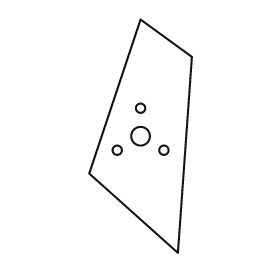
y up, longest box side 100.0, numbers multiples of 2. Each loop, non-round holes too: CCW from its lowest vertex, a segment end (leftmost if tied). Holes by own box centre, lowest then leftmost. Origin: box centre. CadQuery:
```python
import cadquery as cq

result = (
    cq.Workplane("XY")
    .moveTo(16.0, -50.0)
    .lineTo(22.0, 34.0)
    .lineTo(0.0, 50.0)
    .lineTo(-22.0, -16.0)
    .close()
    .moveTo(-10.0, -6.0)
    .circle(2.0)
    .moveTo(10.0, -6.0)
    .circle(2.0)
    .moveTo(0.0, 0.0)
    .circle(4.0)
    .moveTo(0.0, 12.0)
    .circle(2.0)
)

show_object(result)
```